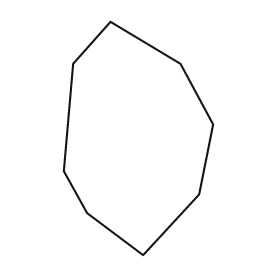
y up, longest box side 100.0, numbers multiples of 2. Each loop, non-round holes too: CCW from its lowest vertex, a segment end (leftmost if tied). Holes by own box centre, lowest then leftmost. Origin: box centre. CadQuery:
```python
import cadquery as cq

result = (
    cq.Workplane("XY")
    .moveTo(2.0, -50.0)
    .lineTo(26.0, -24.0)
    .lineTo(32.0, 6.0)
    .lineTo(18.0, 32.0)
    .lineTo(-12.0, 50.0)
    .lineTo(-28.0, 32.0)
    .lineTo(-32.0, -14.0)
    .lineTo(-22.0, -32.0)
    .close()
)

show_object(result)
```